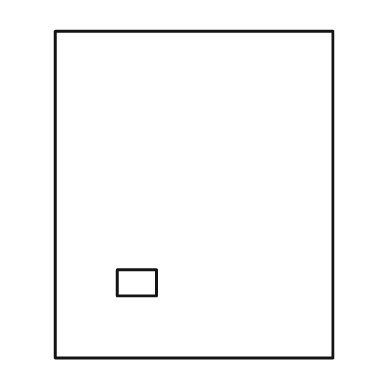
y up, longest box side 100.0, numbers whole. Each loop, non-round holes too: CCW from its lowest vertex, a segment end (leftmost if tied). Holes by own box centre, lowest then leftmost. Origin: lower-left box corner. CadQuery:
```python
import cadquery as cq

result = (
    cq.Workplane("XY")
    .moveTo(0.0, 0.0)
    .lineTo(85.0, 0.0)
    .lineTo(85.0, 100.0)
    .lineTo(0.0, 100.0)
    .close()
    .moveTo(19.0, 19.0)
    .lineTo(31.0, 19.0)
    .lineTo(31.0, 27.0)
    .lineTo(19.0, 27.0)
    .close()
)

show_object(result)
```